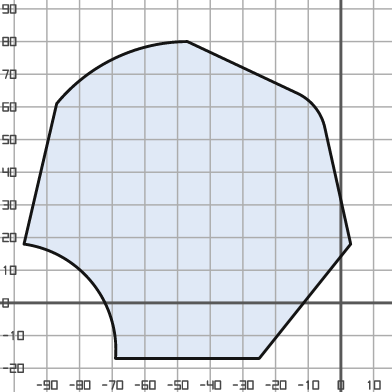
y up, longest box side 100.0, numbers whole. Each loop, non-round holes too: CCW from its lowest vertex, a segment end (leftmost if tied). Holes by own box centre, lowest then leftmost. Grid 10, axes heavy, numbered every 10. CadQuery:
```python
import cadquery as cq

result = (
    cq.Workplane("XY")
    .moveTo(-69.0, -17.0)
    .lineTo(-25.0, -17.0)
    .lineTo(3.0, 18.0)
    .lineTo(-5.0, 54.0)
    .threePointArc((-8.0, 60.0), (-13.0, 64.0))
    .lineTo(-47.0, 80.0)
    .threePointArc((-69.0, 75.0), (-87.0, 61.0))
    .lineTo(-97.0, 18.0)
    .threePointArc((-76.0, 6.0), (-69.0, -17.0))
    .close()
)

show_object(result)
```